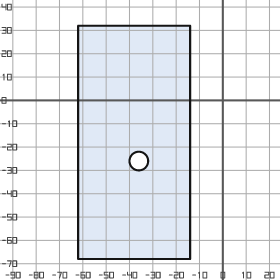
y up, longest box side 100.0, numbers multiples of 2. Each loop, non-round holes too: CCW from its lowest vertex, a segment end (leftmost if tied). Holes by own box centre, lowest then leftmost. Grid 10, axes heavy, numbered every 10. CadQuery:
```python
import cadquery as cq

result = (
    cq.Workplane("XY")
    .moveTo(-62.0, -68.0)
    .lineTo(-14.0, -68.0)
    .lineTo(-14.0, 32.0)
    .lineTo(-62.0, 32.0)
    .close()
    .moveTo(-36.0, -26.0)
    .circle(4.0)
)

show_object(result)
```